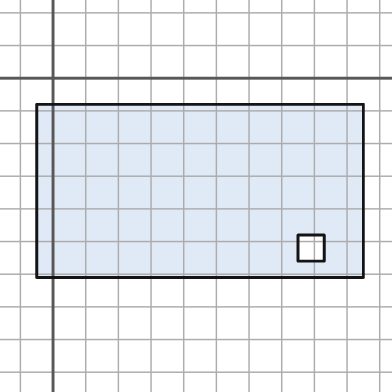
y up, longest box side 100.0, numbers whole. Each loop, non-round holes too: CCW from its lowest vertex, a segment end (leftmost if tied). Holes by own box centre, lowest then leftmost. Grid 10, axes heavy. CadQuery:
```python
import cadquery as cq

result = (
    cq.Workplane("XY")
    .moveTo(-5.0, -61.0)
    .lineTo(95.0, -61.0)
    .lineTo(95.0, -8.0)
    .lineTo(-5.0, -8.0)
    .close()
    .moveTo(75.0, -56.0)
    .lineTo(83.0, -56.0)
    .lineTo(83.0, -48.0)
    .lineTo(75.0, -48.0)
    .close()
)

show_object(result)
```